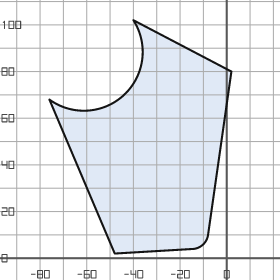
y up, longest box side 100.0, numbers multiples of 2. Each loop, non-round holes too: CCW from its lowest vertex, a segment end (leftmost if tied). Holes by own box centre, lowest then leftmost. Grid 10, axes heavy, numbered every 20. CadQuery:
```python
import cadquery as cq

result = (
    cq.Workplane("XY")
    .moveTo(-48.0, 2.0)
    .lineTo(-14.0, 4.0)
    .threePointArc((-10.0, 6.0), (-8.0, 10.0))
    .lineTo(2.0, 80.0)
    .lineTo(-40.0, 102.0)
    .threePointArc((-44.0, 70.0), (-76.0, 68.0))
    .close()
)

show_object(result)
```